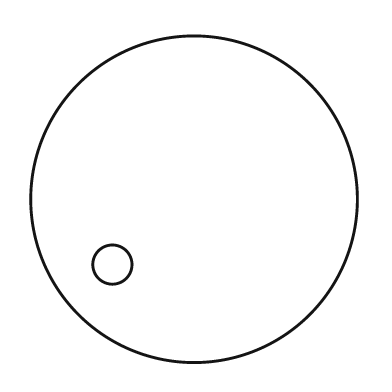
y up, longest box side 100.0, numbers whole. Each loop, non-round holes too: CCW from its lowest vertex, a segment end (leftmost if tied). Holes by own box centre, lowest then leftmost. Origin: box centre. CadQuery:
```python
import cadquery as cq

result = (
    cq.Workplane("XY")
    .moveTo(0.0, 0.0)
    .circle(50.0)
    .moveTo(-25.0, -20.0)
    .circle(6.0)
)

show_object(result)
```